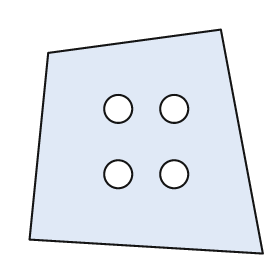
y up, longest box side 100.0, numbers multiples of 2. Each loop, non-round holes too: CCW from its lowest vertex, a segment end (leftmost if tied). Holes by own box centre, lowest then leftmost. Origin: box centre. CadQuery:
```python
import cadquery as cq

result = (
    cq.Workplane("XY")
    .moveTo(50.0, -48.0)
    .lineTo(32.0, 48.0)
    .lineTo(-42.0, 38.0)
    .lineTo(-50.0, -42.0)
    .close()
    .moveTo(-12.0, -14.0)
    .circle(6.0)
    .moveTo(12.0, -14.0)
    .circle(6.0)
    .moveTo(-12.0, 14.0)
    .circle(6.0)
    .moveTo(12.0, 14.0)
    .circle(6.0)
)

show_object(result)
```